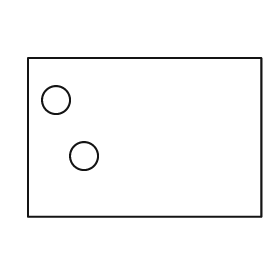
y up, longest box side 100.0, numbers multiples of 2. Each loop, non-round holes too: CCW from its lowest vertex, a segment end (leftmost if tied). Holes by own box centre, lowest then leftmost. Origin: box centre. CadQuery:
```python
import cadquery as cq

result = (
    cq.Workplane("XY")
    .moveTo(-50.0, -34.0)
    .lineTo(50.0, -34.0)
    .lineTo(50.0, 34.0)
    .lineTo(-50.0, 34.0)
    .close()
    .moveTo(-26.0, -8.0)
    .circle(6.0)
    .moveTo(-38.0, 16.0)
    .circle(6.0)
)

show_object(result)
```